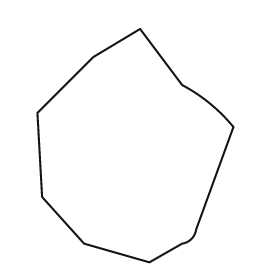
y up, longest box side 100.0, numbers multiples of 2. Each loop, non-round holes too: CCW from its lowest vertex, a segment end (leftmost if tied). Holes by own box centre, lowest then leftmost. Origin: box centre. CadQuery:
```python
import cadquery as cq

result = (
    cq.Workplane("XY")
    .moveTo(6.0, -50.0)
    .lineTo(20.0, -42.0)
    .threePointArc((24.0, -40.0), (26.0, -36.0))
    .lineTo(42.0, 8.0)
    .threePointArc((32.0, 18.0), (20.0, 26.0))
    .lineTo(2.0, 50.0)
    .lineTo(-18.0, 38.0)
    .lineTo(-42.0, 14.0)
    .lineTo(-40.0, -22.0)
    .lineTo(-22.0, -42.0)
    .close()
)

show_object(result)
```